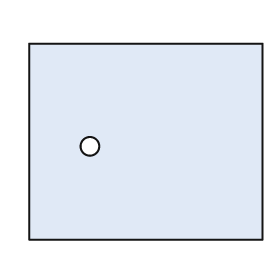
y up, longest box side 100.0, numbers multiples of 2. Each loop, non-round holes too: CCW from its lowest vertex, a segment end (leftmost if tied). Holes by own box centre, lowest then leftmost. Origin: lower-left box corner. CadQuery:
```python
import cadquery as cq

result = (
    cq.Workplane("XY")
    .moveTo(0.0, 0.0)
    .lineTo(100.0, 0.0)
    .lineTo(100.0, 84.0)
    .lineTo(0.0, 84.0)
    .close()
    .moveTo(26.0, 40.0)
    .circle(4.0)
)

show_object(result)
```